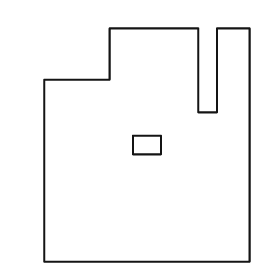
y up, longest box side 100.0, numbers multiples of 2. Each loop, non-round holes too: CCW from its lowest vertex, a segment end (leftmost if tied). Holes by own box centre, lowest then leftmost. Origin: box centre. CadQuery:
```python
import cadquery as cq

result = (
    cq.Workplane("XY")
    .moveTo(-44.0, -50.0)
    .lineTo(44.0, -50.0)
    .lineTo(44.0, 50.0)
    .lineTo(30.0, 50.0)
    .lineTo(30.0, 14.0)
    .lineTo(22.0, 14.0)
    .lineTo(22.0, 50.0)
    .lineTo(-16.0, 50.0)
    .lineTo(-16.0, 28.0)
    .lineTo(-44.0, 28.0)
    .close()
    .moveTo(-6.0, -4.0)
    .lineTo(6.0, -4.0)
    .lineTo(6.0, 4.0)
    .lineTo(-6.0, 4.0)
    .close()
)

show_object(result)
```